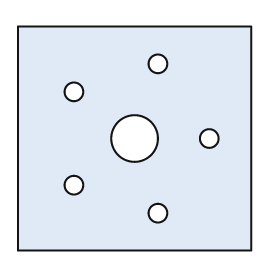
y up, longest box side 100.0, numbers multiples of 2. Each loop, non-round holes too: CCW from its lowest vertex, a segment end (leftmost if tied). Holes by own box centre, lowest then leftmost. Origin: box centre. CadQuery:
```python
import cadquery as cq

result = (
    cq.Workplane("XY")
    .moveTo(-50.0, -48.0)
    .lineTo(50.0, -48.0)
    .lineTo(50.0, 48.0)
    .lineTo(-50.0, 48.0)
    .close()
    .moveTo(10.0, -32.0)
    .circle(4.0)
    .moveTo(-26.0, -20.0)
    .circle(4.0)
    .moveTo(0.0, 0.0)
    .circle(10.0)
    .moveTo(32.0, 0.0)
    .circle(4.0)
    .moveTo(-26.0, 20.0)
    .circle(4.0)
    .moveTo(10.0, 32.0)
    .circle(4.0)
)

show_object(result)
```